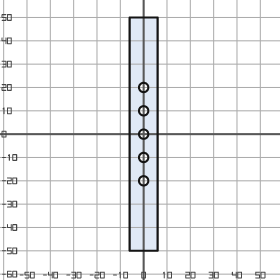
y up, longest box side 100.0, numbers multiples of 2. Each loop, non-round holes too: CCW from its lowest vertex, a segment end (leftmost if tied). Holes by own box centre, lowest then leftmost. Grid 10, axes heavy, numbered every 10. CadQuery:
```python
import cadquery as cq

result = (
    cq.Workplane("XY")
    .moveTo(-6.0, -50.0)
    .lineTo(6.0, -50.0)
    .lineTo(6.0, 50.0)
    .lineTo(-6.0, 50.0)
    .close()
    .moveTo(0.0, -20.0)
    .circle(2.0)
    .moveTo(0.0, -10.0)
    .circle(2.0)
    .moveTo(0.0, 0.0)
    .circle(2.0)
    .moveTo(0.0, 10.0)
    .circle(2.0)
    .moveTo(0.0, 20.0)
    .circle(2.0)
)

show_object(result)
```